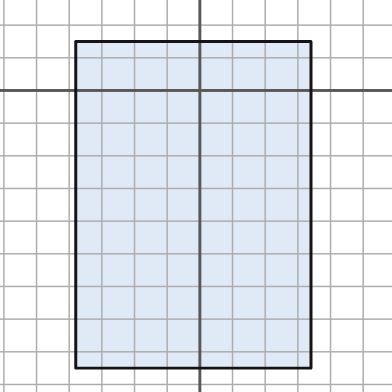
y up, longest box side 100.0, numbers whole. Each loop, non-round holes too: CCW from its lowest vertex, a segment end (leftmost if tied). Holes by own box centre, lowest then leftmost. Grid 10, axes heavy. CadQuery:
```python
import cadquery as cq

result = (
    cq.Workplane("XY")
    .moveTo(-38.0, -85.0)
    .lineTo(34.0, -85.0)
    .lineTo(34.0, 15.0)
    .lineTo(-38.0, 15.0)
    .close()
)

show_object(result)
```